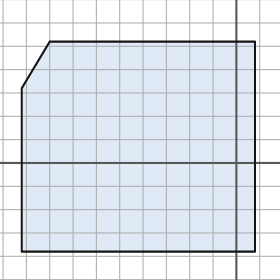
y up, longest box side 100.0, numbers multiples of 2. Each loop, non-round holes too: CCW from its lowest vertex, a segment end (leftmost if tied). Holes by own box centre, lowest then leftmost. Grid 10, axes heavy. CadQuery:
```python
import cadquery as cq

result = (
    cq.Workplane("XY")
    .moveTo(-92.0, -38.0)
    .lineTo(8.0, -38.0)
    .lineTo(8.0, 52.0)
    .lineTo(-80.0, 52.0)
    .lineTo(-92.0, 32.0)
    .close()
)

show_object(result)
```